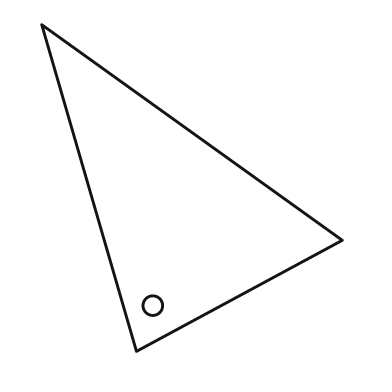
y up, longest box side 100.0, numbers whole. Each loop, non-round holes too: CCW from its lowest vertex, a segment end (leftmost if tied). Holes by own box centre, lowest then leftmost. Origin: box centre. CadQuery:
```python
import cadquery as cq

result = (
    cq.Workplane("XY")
    .moveTo(-17.0, -50.0)
    .lineTo(46.0, -16.0)
    .lineTo(-46.0, 50.0)
    .close()
    .moveTo(-12.0, -36.0)
    .circle(3.0)
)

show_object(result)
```